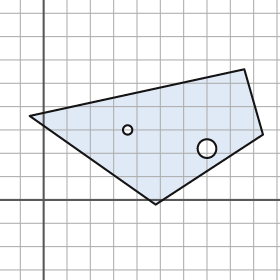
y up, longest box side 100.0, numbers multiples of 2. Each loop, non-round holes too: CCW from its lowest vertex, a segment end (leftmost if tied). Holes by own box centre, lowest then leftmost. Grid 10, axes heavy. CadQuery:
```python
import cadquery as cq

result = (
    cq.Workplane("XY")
    .moveTo(48.0, -2.0)
    .lineTo(94.0, 28.0)
    .lineTo(86.0, 56.0)
    .lineTo(-6.0, 36.0)
    .close()
    .moveTo(70.0, 22.0)
    .circle(4.0)
    .moveTo(36.0, 30.0)
    .circle(2.0)
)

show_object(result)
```